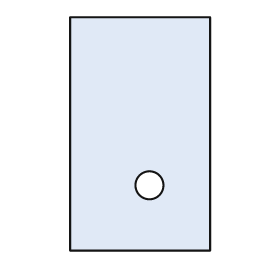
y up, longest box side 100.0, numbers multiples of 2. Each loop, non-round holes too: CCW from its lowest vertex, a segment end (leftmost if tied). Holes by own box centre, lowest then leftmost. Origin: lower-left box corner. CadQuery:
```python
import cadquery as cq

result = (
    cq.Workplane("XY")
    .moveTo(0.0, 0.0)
    .lineTo(60.0, 0.0)
    .lineTo(60.0, 100.0)
    .lineTo(0.0, 100.0)
    .close()
    .moveTo(34.0, 28.0)
    .circle(6.0)
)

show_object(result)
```